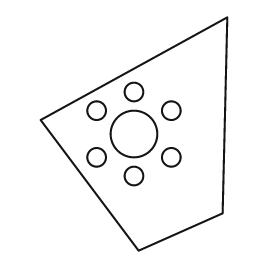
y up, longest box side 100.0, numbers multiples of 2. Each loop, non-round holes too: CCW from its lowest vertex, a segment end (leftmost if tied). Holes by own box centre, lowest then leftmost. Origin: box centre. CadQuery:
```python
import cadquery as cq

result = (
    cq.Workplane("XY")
    .moveTo(2.0, -50.0)
    .lineTo(38.0, -34.0)
    .lineTo(40.0, 50.0)
    .lineTo(-40.0, 6.0)
    .close()
    .moveTo(0.0, -18.0)
    .circle(4.0)
    .moveTo(-16.0, -10.0)
    .circle(4.0)
    .moveTo(16.0, -10.0)
    .circle(4.0)
    .moveTo(0.0, 0.0)
    .circle(10.0)
    .moveTo(-16.0, 10.0)
    .circle(4.0)
    .moveTo(16.0, 10.0)
    .circle(4.0)
    .moveTo(0.0, 18.0)
    .circle(4.0)
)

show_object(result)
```